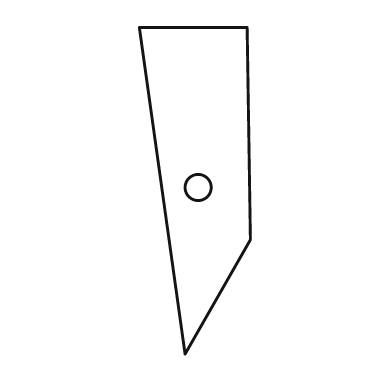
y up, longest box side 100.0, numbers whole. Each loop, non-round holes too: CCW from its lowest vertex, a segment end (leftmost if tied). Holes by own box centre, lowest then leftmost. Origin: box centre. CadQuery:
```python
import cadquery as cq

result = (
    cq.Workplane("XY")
    .moveTo(-3.0, -50.0)
    .lineTo(17.0, -15.0)
    .lineTo(16.0, 50.0)
    .lineTo(-17.0, 50.0)
    .close()
    .moveTo(1.0, 1.0)
    .circle(4.0)
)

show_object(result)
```